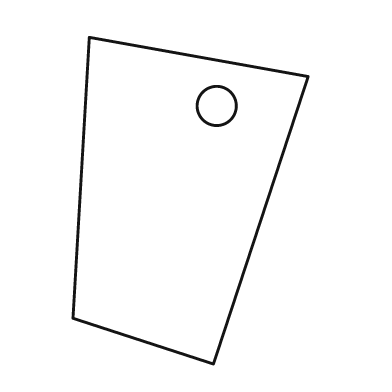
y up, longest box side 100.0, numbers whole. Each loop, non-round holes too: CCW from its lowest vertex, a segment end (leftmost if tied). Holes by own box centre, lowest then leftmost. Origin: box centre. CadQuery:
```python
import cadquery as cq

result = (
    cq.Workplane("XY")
    .moveTo(7.0, -50.0)
    .lineTo(36.0, 38.0)
    .lineTo(-31.0, 50.0)
    .lineTo(-36.0, -36.0)
    .close()
    .moveTo(8.0, 29.0)
    .circle(6.0)
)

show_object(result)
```